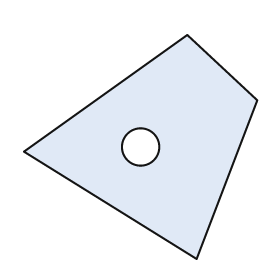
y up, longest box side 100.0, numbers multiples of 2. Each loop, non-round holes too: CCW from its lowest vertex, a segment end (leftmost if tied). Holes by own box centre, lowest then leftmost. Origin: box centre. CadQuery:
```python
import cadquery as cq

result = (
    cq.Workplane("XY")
    .moveTo(24.0, -48.0)
    .lineTo(50.0, 20.0)
    .lineTo(20.0, 48.0)
    .lineTo(-50.0, -2.0)
    .close()
    .moveTo(0.0, 0.0)
    .circle(8.0)
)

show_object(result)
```